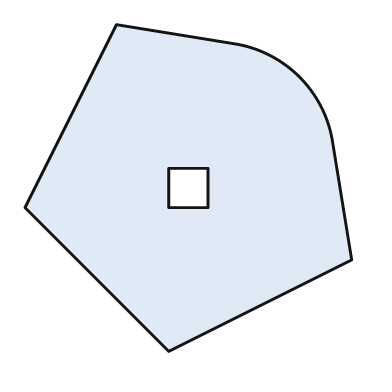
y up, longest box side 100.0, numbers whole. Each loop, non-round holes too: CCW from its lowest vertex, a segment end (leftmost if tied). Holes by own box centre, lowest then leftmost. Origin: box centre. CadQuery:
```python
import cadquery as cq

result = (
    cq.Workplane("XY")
    .moveTo(-6.0, -50.0)
    .lineTo(50.0, -22.0)
    .lineTo(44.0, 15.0)
    .threePointArc((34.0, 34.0), (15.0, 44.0))
    .lineTo(-22.0, 50.0)
    .lineTo(-50.0, -6.0)
    .close()
    .moveTo(-6.0, -6.0)
    .lineTo(6.0, -6.0)
    .lineTo(6.0, 6.0)
    .lineTo(-6.0, 6.0)
    .close()
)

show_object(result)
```